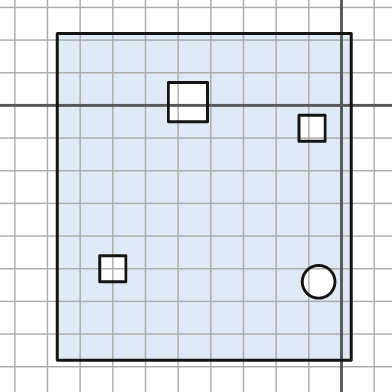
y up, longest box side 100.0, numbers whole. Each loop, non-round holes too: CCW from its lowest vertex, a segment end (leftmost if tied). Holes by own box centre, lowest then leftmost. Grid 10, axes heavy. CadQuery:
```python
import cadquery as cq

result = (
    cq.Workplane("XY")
    .moveTo(-87.0, -78.0)
    .lineTo(3.0, -78.0)
    .lineTo(3.0, 22.0)
    .lineTo(-87.0, 22.0)
    .close()
    .moveTo(-7.0, -54.0)
    .circle(5.0)
    .moveTo(-74.0, -54.0)
    .lineTo(-66.0, -54.0)
    .lineTo(-66.0, -46.0)
    .lineTo(-74.0, -46.0)
    .close()
    .moveTo(-13.0, -11.0)
    .lineTo(-5.0, -11.0)
    .lineTo(-5.0, -3.0)
    .lineTo(-13.0, -3.0)
    .close()
    .moveTo(-53.0, -5.0)
    .lineTo(-41.0, -5.0)
    .lineTo(-41.0, 7.0)
    .lineTo(-53.0, 7.0)
    .close()
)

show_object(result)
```